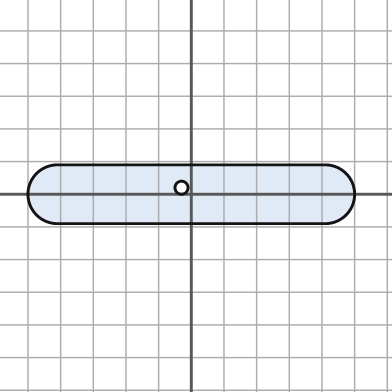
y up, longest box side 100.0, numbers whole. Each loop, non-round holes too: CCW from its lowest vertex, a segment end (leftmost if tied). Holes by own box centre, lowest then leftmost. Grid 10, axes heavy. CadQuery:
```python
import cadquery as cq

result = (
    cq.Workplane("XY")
    .moveTo(-41.0, -9.0)
    .lineTo(41.0, -9.0)
    .threePointArc((50.0, 0.0), (41.0, 9.0))
    .lineTo(-41.0, 9.0)
    .threePointArc((-50.0, 0.0), (-41.0, -9.0))
    .close()
    .moveTo(-3.0, 2.0)
    .circle(2.0)
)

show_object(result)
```